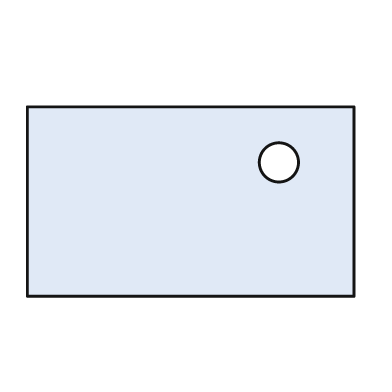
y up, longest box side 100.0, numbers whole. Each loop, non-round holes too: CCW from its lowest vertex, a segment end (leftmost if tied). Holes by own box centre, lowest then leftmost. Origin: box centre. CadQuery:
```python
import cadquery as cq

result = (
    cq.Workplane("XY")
    .moveTo(-50.0, -29.0)
    .lineTo(50.0, -29.0)
    .lineTo(50.0, 29.0)
    .lineTo(-50.0, 29.0)
    .close()
    .moveTo(27.0, 12.0)
    .circle(6.0)
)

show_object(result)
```